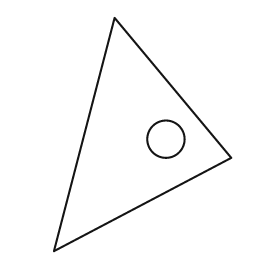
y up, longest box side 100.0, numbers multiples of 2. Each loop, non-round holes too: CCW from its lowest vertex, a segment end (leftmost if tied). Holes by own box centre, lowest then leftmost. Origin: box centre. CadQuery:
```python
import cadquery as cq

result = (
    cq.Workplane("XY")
    .moveTo(-38.0, -50.0)
    .lineTo(38.0, -10.0)
    .lineTo(-12.0, 50.0)
    .close()
    .moveTo(10.0, -2.0)
    .circle(8.0)
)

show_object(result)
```